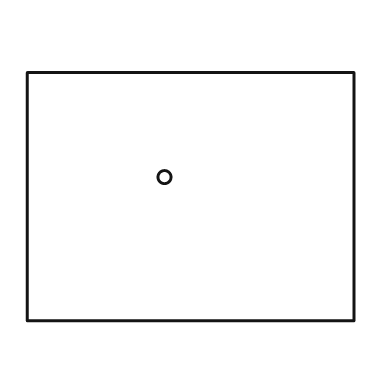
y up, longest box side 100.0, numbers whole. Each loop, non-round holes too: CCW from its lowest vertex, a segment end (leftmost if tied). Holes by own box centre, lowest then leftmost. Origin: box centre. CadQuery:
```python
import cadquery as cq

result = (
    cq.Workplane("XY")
    .moveTo(-50.0, -38.0)
    .lineTo(50.0, -38.0)
    .lineTo(50.0, 38.0)
    .lineTo(-50.0, 38.0)
    .close()
    .moveTo(-8.0, 6.0)
    .circle(2.0)
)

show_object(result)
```